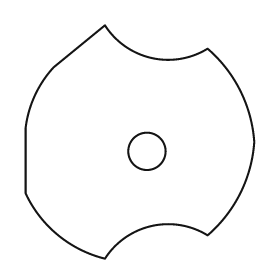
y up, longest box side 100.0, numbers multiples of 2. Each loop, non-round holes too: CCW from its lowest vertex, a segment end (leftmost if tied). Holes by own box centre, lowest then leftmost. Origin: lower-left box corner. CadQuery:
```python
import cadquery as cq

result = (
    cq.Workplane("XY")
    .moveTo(34.0, 0.0)
    .threePointArc((54.0, 14.0), (78.0, 10.0))
    .threePointArc((92.0, 28.0), (98.0, 50.0))
    .threePointArc((92.0, 72.0), (78.0, 90.0))
    .threePointArc((54.0, 86.0), (34.0, 100.0))
    .lineTo(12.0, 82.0)
    .threePointArc((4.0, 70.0), (0.0, 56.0))
    .lineTo(0.0, 28.0)
    .threePointArc((14.0, 10.0), (34.0, 0.0))
    .close()
    .moveTo(52.0, 46.0)
    .circle(8.0)
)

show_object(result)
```